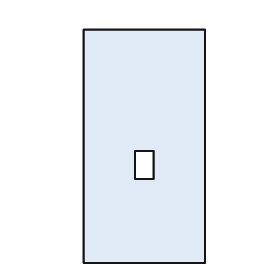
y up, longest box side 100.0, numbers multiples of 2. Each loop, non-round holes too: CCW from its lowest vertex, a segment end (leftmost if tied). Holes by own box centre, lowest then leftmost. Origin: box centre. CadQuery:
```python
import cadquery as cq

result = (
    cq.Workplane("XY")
    .moveTo(-26.0, -50.0)
    .lineTo(26.0, -50.0)
    .lineTo(26.0, 50.0)
    .lineTo(-26.0, 50.0)
    .close()
    .moveTo(-4.0, -14.0)
    .lineTo(4.0, -14.0)
    .lineTo(4.0, -2.0)
    .lineTo(-4.0, -2.0)
    .close()
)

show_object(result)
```